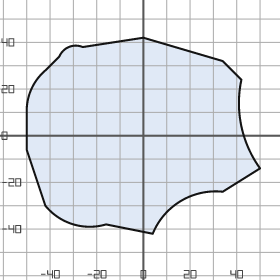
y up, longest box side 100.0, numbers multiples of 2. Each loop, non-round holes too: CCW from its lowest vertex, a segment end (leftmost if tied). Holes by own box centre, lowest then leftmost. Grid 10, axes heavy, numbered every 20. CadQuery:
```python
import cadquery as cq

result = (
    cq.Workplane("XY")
    .moveTo(4.0, -42.0)
    .threePointArc((16.0, -28.0), (34.0, -24.0))
    .lineTo(50.0, -14.0)
    .threePointArc((42.0, 4.0), (42.0, 24.0))
    .lineTo(34.0, 32.0)
    .lineTo(0.0, 42.0)
    .lineTo(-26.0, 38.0)
    .threePointArc((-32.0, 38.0), (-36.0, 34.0))
    .lineTo(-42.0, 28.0)
    .threePointArc((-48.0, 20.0), (-50.0, 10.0))
    .lineTo(-50.0, -6.0)
    .lineTo(-42.0, -30.0)
    .threePointArc((-30.0, -38.0), (-16.0, -38.0))
    .close()
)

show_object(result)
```